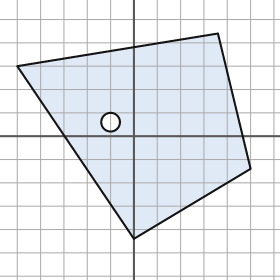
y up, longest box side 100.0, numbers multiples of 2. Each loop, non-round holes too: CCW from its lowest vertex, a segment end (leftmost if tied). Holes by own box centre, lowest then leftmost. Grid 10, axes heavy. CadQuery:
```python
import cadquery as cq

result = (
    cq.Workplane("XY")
    .moveTo(0.0, -44.0)
    .lineTo(50.0, -14.0)
    .lineTo(36.0, 44.0)
    .lineTo(-50.0, 30.0)
    .close()
    .moveTo(-10.0, 6.0)
    .circle(4.0)
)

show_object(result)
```